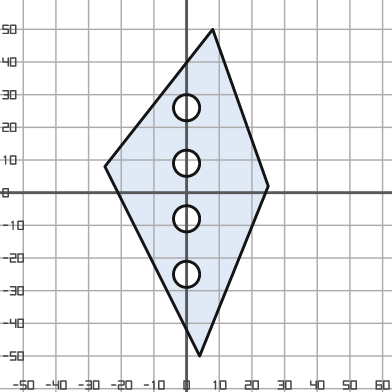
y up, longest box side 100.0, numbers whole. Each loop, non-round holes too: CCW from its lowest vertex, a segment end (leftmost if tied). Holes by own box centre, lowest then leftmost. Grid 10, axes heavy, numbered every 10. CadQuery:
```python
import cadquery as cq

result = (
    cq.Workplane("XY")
    .moveTo(4.0, -50.0)
    .lineTo(25.0, 2.0)
    .lineTo(8.0, 50.0)
    .lineTo(-25.0, 8.0)
    .close()
    .moveTo(0.0, -25.0)
    .circle(4.0)
    .moveTo(0.0, -8.0)
    .circle(4.0)
    .moveTo(0.0, 9.0)
    .circle(4.0)
    .moveTo(0.0, 26.0)
    .circle(4.0)
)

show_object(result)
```